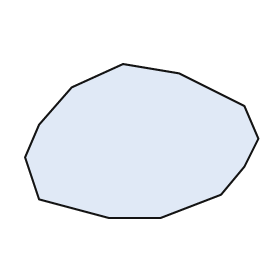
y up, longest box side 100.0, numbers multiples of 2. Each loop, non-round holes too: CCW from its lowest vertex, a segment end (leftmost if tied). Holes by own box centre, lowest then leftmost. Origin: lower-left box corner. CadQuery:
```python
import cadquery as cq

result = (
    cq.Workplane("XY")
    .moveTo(36.0, 0.0)
    .lineTo(58.0, 0.0)
    .lineTo(84.0, 10.0)
    .lineTo(94.0, 22.0)
    .lineTo(100.0, 34.0)
    .lineTo(94.0, 48.0)
    .lineTo(66.0, 62.0)
    .lineTo(42.0, 66.0)
    .lineTo(20.0, 56.0)
    .lineTo(6.0, 40.0)
    .lineTo(0.0, 26.0)
    .lineTo(6.0, 8.0)
    .close()
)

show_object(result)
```